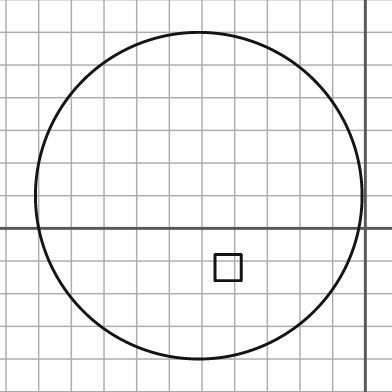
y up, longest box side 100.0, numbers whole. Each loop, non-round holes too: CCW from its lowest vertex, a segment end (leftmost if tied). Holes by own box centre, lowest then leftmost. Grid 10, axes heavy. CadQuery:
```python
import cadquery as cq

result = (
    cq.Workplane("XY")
    .moveTo(-51.0, 10.0)
    .circle(50.0)
    .moveTo(-46.0, -16.0)
    .lineTo(-38.0, -16.0)
    .lineTo(-38.0, -8.0)
    .lineTo(-46.0, -8.0)
    .close()
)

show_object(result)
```